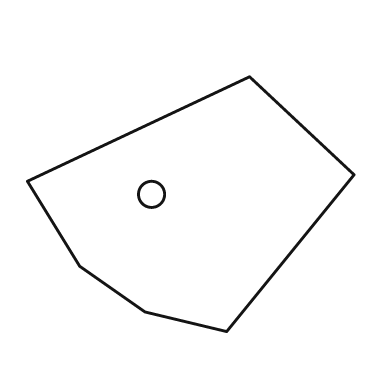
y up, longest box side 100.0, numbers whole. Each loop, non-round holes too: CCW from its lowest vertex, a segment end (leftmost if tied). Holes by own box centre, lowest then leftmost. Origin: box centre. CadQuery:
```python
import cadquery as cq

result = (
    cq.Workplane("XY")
    .moveTo(11.0, -39.0)
    .lineTo(50.0, 9.0)
    .lineTo(18.0, 39.0)
    .lineTo(-50.0, 7.0)
    .lineTo(-34.0, -19.0)
    .lineTo(-14.0, -33.0)
    .close()
    .moveTo(-12.0, 3.0)
    .circle(4.0)
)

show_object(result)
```